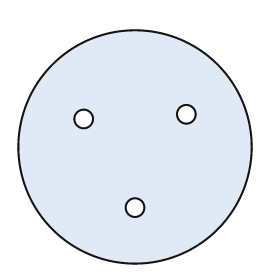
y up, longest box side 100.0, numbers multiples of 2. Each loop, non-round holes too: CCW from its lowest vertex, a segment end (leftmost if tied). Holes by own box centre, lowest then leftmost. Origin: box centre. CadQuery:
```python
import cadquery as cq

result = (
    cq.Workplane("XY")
    .moveTo(0.0, 0.0)
    .circle(50.0)
    .moveTo(0.0, -26.0)
    .circle(4.0)
    .moveTo(-22.0, 12.0)
    .circle(4.0)
    .moveTo(22.0, 14.0)
    .circle(4.0)
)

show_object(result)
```